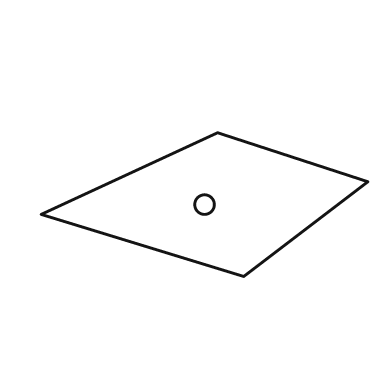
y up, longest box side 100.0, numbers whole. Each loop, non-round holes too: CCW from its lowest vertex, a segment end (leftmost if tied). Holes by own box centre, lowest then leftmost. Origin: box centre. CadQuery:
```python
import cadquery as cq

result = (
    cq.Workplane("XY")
    .moveTo(12.0, -22.0)
    .lineTo(50.0, 7.0)
    .lineTo(4.0, 22.0)
    .lineTo(-50.0, -3.0)
    .close()
    .moveTo(0.0, 0.0)
    .circle(3.0)
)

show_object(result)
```